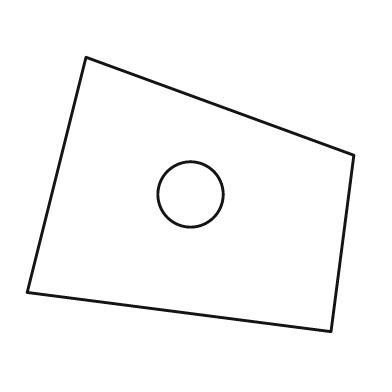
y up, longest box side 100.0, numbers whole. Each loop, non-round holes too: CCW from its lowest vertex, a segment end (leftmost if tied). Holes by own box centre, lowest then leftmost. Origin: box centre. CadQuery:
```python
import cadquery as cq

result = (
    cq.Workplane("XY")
    .moveTo(43.0, -42.0)
    .lineTo(50.0, 12.0)
    .lineTo(-32.0, 42.0)
    .lineTo(-50.0, -30.0)
    .close()
    .moveTo(0.0, 0.0)
    .circle(10.0)
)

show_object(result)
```